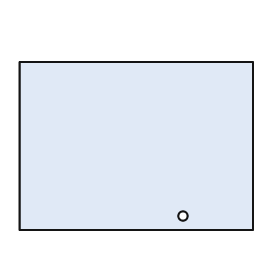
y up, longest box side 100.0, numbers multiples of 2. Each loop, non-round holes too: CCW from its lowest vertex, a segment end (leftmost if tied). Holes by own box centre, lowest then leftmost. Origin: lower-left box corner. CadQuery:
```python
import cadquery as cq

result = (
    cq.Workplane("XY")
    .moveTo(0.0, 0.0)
    .lineTo(100.0, 0.0)
    .lineTo(100.0, 72.0)
    .lineTo(0.0, 72.0)
    .close()
    .moveTo(70.0, 6.0)
    .circle(2.0)
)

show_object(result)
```